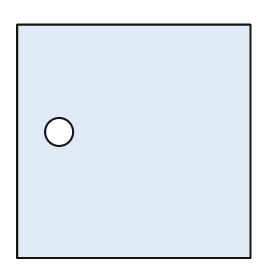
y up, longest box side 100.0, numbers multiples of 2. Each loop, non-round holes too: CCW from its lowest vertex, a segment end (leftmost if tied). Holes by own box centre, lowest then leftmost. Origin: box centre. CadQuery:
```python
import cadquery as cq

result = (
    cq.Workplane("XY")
    .moveTo(-50.0, -50.0)
    .lineTo(50.0, -50.0)
    .lineTo(50.0, 50.0)
    .lineTo(-50.0, 50.0)
    .close()
    .moveTo(-32.0, 4.0)
    .circle(6.0)
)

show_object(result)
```